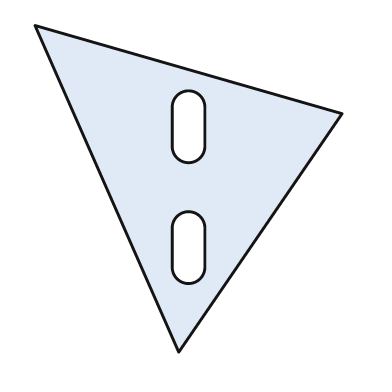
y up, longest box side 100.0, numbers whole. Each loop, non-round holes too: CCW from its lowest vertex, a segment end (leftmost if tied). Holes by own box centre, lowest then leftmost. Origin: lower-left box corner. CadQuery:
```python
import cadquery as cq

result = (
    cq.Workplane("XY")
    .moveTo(44.0, 0.0)
    .lineTo(94.0, 73.0)
    .lineTo(0.0, 100.0)
    .close()
    .moveTo(42.0, 26.0)
    .threePointArc((47.0, 21.0), (52.0, 26.0))
    .lineTo(52.0, 38.0)
    .threePointArc((47.0, 43.0), (42.0, 38.0))
    .close()
    .moveTo(42.0, 63.0)
    .threePointArc((47.0, 58.0), (52.0, 63.0))
    .lineTo(52.0, 75.0)
    .threePointArc((47.0, 80.0), (42.0, 75.0))
    .close()
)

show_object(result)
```